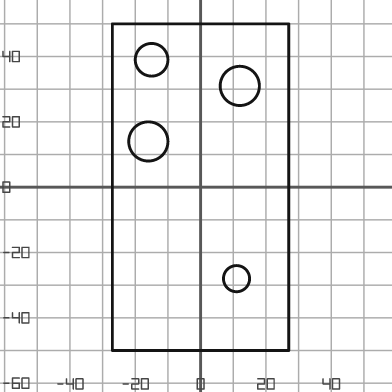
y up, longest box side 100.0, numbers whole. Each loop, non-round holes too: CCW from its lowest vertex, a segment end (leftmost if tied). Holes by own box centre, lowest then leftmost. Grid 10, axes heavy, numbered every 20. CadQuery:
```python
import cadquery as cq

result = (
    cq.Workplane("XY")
    .moveTo(-27.0, -50.0)
    .lineTo(27.0, -50.0)
    .lineTo(27.0, 50.0)
    .lineTo(-27.0, 50.0)
    .close()
    .moveTo(11.0, -28.0)
    .circle(4.0)
    .moveTo(-16.0, 14.0)
    .circle(6.0)
    .moveTo(12.0, 31.0)
    .circle(6.0)
    .moveTo(-15.0, 39.0)
    .circle(5.0)
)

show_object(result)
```